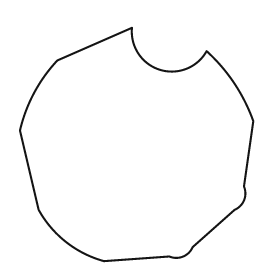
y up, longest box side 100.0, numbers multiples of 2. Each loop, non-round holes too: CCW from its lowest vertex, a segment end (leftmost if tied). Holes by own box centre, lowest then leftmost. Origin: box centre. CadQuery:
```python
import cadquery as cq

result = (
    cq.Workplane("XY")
    .moveTo(-14.0, -50.0)
    .lineTo(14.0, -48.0)
    .threePointArc((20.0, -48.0), (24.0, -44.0))
    .lineTo(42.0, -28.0)
    .threePointArc((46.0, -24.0), (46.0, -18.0))
    .lineTo(50.0, 10.0)
    .threePointArc((42.0, 26.0), (30.0, 40.0))
    .threePointArc((10.0, 32.0), (-2.0, 50.0))
    .lineTo(-34.0, 36.0)
    .threePointArc((-44.0, 22.0), (-50.0, 6.0))
    .lineTo(-42.0, -28.0)
    .threePointArc((-30.0, -42.0), (-14.0, -50.0))
    .close()
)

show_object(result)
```